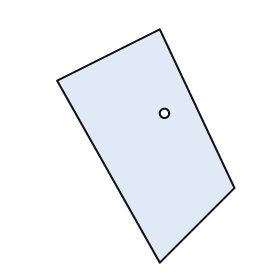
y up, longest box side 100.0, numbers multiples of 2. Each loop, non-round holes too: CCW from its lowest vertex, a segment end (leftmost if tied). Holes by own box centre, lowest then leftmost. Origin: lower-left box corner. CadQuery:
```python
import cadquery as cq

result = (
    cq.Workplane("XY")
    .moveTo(44.0, 0.0)
    .lineTo(76.0, 32.0)
    .lineTo(44.0, 100.0)
    .lineTo(0.0, 78.0)
    .close()
    .moveTo(46.0, 64.0)
    .circle(2.0)
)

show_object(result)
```